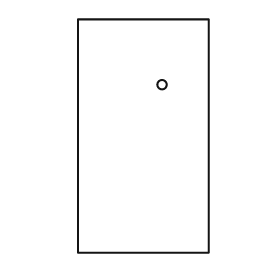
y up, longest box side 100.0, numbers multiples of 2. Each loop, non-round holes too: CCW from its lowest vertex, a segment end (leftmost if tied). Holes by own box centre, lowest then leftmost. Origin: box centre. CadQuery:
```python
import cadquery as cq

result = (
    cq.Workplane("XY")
    .moveTo(-28.0, -50.0)
    .lineTo(28.0, -50.0)
    .lineTo(28.0, 50.0)
    .lineTo(-28.0, 50.0)
    .close()
    .moveTo(8.0, 22.0)
    .circle(2.0)
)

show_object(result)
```